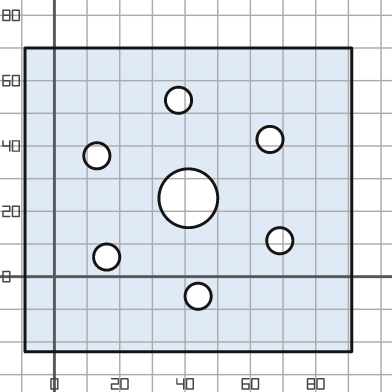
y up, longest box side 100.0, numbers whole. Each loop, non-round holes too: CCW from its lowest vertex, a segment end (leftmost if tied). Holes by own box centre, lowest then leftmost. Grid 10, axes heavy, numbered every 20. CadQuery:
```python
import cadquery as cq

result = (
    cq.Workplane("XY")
    .moveTo(-9.0, -23.0)
    .lineTo(91.0, -23.0)
    .lineTo(91.0, 70.0)
    .lineTo(-9.0, 70.0)
    .close()
    .moveTo(44.0, -6.0)
    .circle(4.0)
    .moveTo(16.0, 6.0)
    .circle(4.0)
    .moveTo(69.0, 11.0)
    .circle(4.0)
    .moveTo(41.0, 24.0)
    .circle(9.0)
    .moveTo(13.0, 37.0)
    .circle(4.0)
    .moveTo(66.0, 42.0)
    .circle(4.0)
    .moveTo(38.0, 54.0)
    .circle(4.0)
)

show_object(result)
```